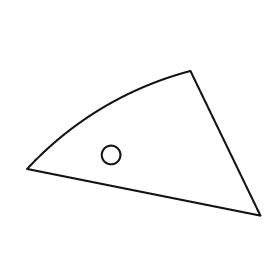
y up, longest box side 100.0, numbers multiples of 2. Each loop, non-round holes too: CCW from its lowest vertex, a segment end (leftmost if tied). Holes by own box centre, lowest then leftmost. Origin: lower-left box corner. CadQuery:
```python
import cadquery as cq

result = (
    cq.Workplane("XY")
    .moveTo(100.0, 0.0)
    .lineTo(70.0, 62.0)
    .threePointArc((32.0, 46.0), (0.0, 20.0))
    .close()
    .moveTo(36.0, 26.0)
    .circle(4.0)
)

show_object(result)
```